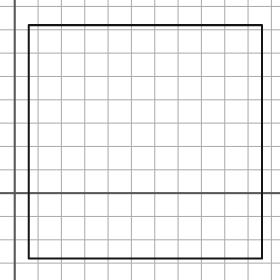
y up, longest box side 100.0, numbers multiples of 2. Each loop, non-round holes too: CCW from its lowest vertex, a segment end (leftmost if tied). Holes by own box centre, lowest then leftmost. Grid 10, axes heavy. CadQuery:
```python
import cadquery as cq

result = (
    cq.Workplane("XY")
    .moveTo(6.0, -28.0)
    .lineTo(106.0, -28.0)
    .lineTo(106.0, 72.0)
    .lineTo(6.0, 72.0)
    .close()
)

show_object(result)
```